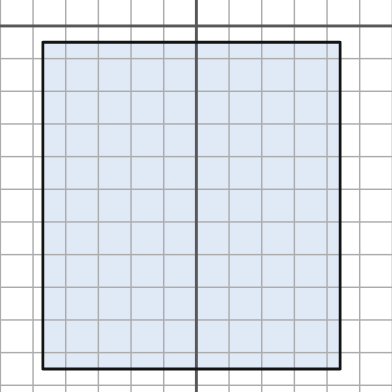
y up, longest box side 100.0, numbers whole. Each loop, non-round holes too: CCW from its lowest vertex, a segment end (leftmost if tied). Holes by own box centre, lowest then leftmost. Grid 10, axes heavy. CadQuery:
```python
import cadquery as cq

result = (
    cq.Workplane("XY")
    .moveTo(-47.0, -105.0)
    .lineTo(44.0, -105.0)
    .lineTo(44.0, -5.0)
    .lineTo(-47.0, -5.0)
    .close()
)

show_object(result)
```